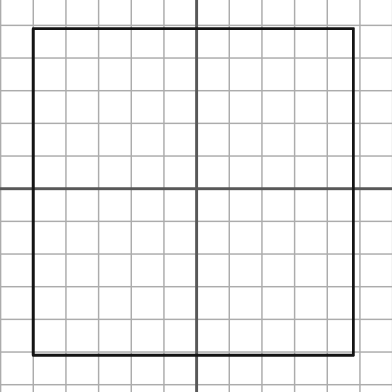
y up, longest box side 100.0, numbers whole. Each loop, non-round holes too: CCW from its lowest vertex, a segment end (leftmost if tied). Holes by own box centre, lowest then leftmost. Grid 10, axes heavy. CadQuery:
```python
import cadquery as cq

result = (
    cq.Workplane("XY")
    .moveTo(-50.0, -51.0)
    .lineTo(48.0, -51.0)
    .lineTo(48.0, 49.0)
    .lineTo(-50.0, 49.0)
    .close()
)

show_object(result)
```